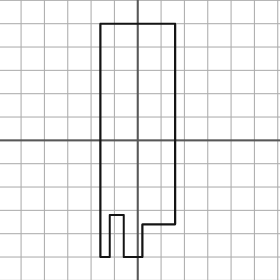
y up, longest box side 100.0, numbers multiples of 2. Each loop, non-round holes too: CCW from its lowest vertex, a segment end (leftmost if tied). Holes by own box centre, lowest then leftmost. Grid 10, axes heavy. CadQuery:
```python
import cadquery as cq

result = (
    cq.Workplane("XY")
    .moveTo(-16.0, -50.0)
    .lineTo(-12.0, -50.0)
    .lineTo(-12.0, -32.0)
    .lineTo(-6.0, -32.0)
    .lineTo(-6.0, -50.0)
    .lineTo(2.0, -50.0)
    .lineTo(2.0, -36.0)
    .lineTo(16.0, -36.0)
    .lineTo(16.0, 50.0)
    .lineTo(-16.0, 50.0)
    .close()
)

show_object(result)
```